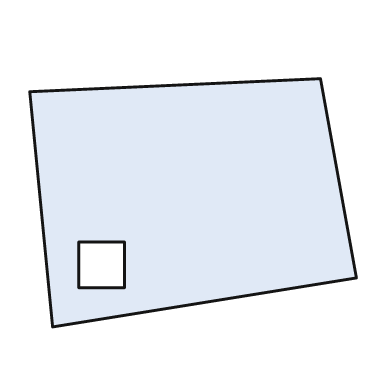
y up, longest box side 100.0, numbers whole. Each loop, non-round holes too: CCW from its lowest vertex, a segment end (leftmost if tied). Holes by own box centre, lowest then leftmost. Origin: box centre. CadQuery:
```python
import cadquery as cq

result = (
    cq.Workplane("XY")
    .moveTo(-43.0, -38.0)
    .lineTo(50.0, -23.0)
    .lineTo(39.0, 38.0)
    .lineTo(-50.0, 34.0)
    .close()
    .moveTo(-35.0, -26.0)
    .lineTo(-21.0, -26.0)
    .lineTo(-21.0, -12.0)
    .lineTo(-35.0, -12.0)
    .close()
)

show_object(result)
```